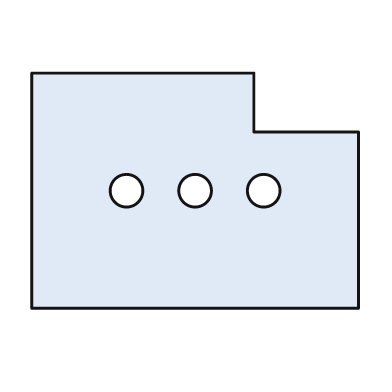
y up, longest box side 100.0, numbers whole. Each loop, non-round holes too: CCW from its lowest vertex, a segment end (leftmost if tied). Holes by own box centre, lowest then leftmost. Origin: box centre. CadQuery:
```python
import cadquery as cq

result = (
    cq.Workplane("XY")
    .moveTo(-50.0, -36.0)
    .lineTo(50.0, -36.0)
    .lineTo(50.0, 18.0)
    .lineTo(18.0, 18.0)
    .lineTo(18.0, 36.0)
    .lineTo(-50.0, 36.0)
    .close()
    .moveTo(-21.0, 0.0)
    .circle(5.0)
    .moveTo(0.0, 0.0)
    .circle(5.0)
    .moveTo(21.0, 0.0)
    .circle(5.0)
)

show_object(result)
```